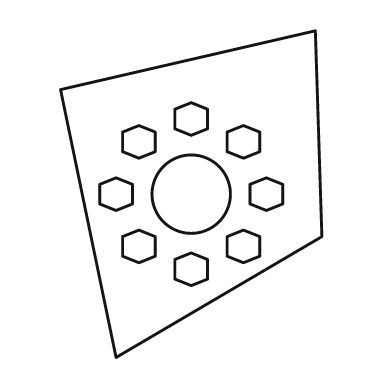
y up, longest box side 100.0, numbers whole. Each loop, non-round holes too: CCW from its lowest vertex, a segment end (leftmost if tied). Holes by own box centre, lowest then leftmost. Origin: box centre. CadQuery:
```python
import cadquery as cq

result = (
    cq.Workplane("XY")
    .moveTo(-23.0, -50.0)
    .lineTo(40.0, -13.0)
    .lineTo(38.0, 50.0)
    .lineTo(-40.0, 32.0)
    .close()
    .moveTo(0.0, -28.0)
    .lineTo(5.0, -26.0)
    .lineTo(5.0, -20.0)
    .lineTo(0.0, -18.0)
    .lineTo(-5.0, -20.0)
    .lineTo(-5.0, -26.0)
    .close()
    .moveTo(-16.0, -21.0)
    .lineTo(-11.0, -19.0)
    .lineTo(-11.0, -13.0)
    .lineTo(-16.0, -11.0)
    .lineTo(-21.0, -13.0)
    .lineTo(-21.0, -19.0)
    .close()
    .moveTo(16.0, -21.0)
    .lineTo(21.0, -19.0)
    .lineTo(21.0, -13.0)
    .lineTo(16.0, -11.0)
    .lineTo(11.0, -13.0)
    .lineTo(11.0, -19.0)
    .close()
    .moveTo(-23.0, -5.0)
    .lineTo(-18.0, -3.0)
    .lineTo(-18.0, 3.0)
    .lineTo(-23.0, 5.0)
    .lineTo(-28.0, 3.0)
    .lineTo(-28.0, -3.0)
    .close()
    .moveTo(0.0, 0.0)
    .circle(12.0)
    .moveTo(23.0, -5.0)
    .lineTo(28.0, -3.0)
    .lineTo(28.0, 3.0)
    .lineTo(23.0, 5.0)
    .lineTo(18.0, 3.0)
    .lineTo(18.0, -3.0)
    .close()
    .moveTo(-16.0, 11.0)
    .lineTo(-11.0, 13.0)
    .lineTo(-11.0, 19.0)
    .lineTo(-16.0, 21.0)
    .lineTo(-21.0, 19.0)
    .lineTo(-21.0, 13.0)
    .close()
    .moveTo(16.0, 11.0)
    .lineTo(21.0, 13.0)
    .lineTo(21.0, 19.0)
    .lineTo(16.0, 21.0)
    .lineTo(11.0, 19.0)
    .lineTo(11.0, 13.0)
    .close()
    .moveTo(0.0, 18.0)
    .lineTo(5.0, 20.0)
    .lineTo(5.0, 26.0)
    .lineTo(0.0, 28.0)
    .lineTo(-5.0, 26.0)
    .lineTo(-5.0, 20.0)
    .close()
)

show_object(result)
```